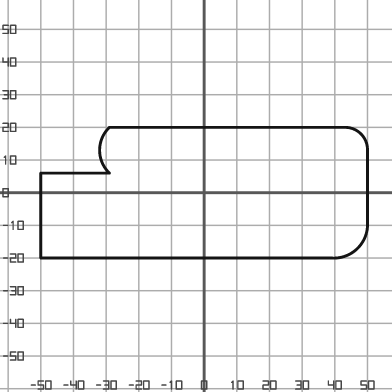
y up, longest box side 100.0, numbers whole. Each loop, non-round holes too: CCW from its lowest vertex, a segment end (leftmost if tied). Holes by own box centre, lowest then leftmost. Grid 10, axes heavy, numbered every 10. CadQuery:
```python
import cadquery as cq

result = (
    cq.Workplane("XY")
    .moveTo(-50.0, -20.0)
    .lineTo(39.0, -20.0)
    .threePointArc((47.0, -17.0), (50.0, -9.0))
    .lineTo(50.0, 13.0)
    .threePointArc((48.0, 18.0), (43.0, 20.0))
    .lineTo(-29.0, 20.0)
    .threePointArc((-32.0, 13.0), (-29.0, 6.0))
    .lineTo(-50.0, 6.0)
    .close()
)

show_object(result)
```